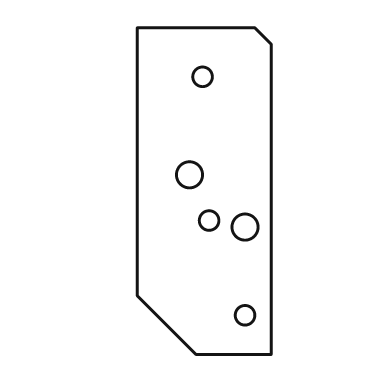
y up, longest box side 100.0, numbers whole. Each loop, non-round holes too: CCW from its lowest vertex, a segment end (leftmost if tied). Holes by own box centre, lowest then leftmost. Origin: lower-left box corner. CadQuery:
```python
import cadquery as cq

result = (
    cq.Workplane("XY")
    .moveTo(18.0, 0.0)
    .lineTo(41.0, 0.0)
    .lineTo(41.0, 95.0)
    .lineTo(36.0, 100.0)
    .lineTo(0.0, 100.0)
    .lineTo(0.0, 18.0)
    .close()
    .moveTo(33.0, 12.0)
    .circle(3.0)
    .moveTo(33.0, 39.0)
    .circle(4.0)
    .moveTo(22.0, 41.0)
    .circle(3.0)
    .moveTo(16.0, 55.0)
    .circle(4.0)
    .moveTo(20.0, 85.0)
    .circle(3.0)
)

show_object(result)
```